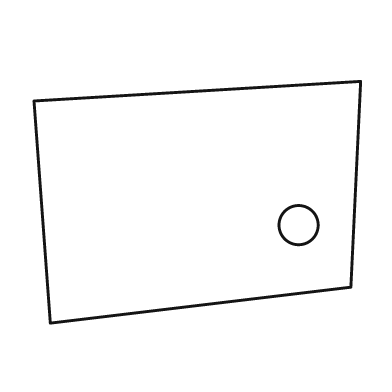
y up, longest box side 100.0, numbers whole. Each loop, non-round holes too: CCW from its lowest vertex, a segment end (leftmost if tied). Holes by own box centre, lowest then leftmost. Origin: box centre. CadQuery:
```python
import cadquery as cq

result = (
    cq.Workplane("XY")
    .moveTo(-45.0, -37.0)
    .lineTo(47.0, -26.0)
    .lineTo(50.0, 37.0)
    .lineTo(-50.0, 31.0)
    .close()
    .moveTo(31.0, -7.0)
    .circle(6.0)
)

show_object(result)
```